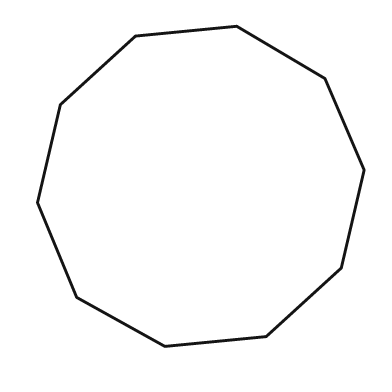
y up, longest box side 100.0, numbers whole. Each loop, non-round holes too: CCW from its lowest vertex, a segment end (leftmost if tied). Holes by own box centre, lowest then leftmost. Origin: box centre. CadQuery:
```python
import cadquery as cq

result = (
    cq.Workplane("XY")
    .moveTo(-11.0, -49.0)
    .lineTo(20.0, -46.0)
    .lineTo(43.0, -25.0)
    .lineTo(50.0, 5.0)
    .lineTo(38.0, 33.0)
    .lineTo(11.0, 49.0)
    .lineTo(-20.0, 46.0)
    .lineTo(-43.0, 25.0)
    .lineTo(-50.0, -5.0)
    .lineTo(-38.0, -34.0)
    .close()
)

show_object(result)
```